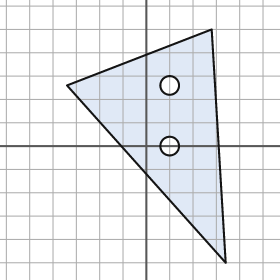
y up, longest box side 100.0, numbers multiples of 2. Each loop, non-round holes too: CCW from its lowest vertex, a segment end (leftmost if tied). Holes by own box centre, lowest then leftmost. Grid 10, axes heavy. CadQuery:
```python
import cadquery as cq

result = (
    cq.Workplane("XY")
    .moveTo(34.0, -50.0)
    .lineTo(28.0, 50.0)
    .lineTo(-34.0, 26.0)
    .close()
    .moveTo(10.0, 0.0)
    .circle(4.0)
    .moveTo(10.0, 26.0)
    .circle(4.0)
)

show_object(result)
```